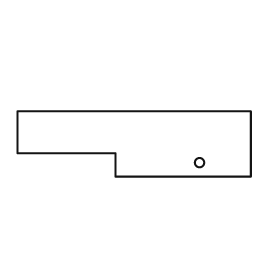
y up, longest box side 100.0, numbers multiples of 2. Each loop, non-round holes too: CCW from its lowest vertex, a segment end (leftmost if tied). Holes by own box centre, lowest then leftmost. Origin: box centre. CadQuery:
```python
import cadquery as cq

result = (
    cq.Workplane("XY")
    .moveTo(-8.0, -14.0)
    .lineTo(50.0, -14.0)
    .lineTo(50.0, 14.0)
    .lineTo(-50.0, 14.0)
    .lineTo(-50.0, -4.0)
    .lineTo(-8.0, -4.0)
    .close()
    .moveTo(28.0, -8.0)
    .circle(2.0)
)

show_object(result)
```